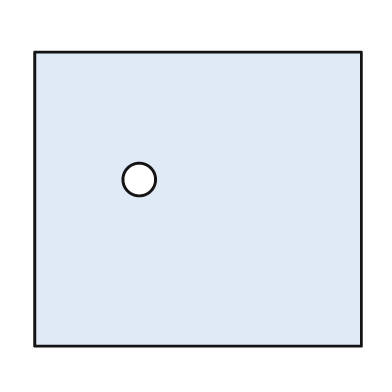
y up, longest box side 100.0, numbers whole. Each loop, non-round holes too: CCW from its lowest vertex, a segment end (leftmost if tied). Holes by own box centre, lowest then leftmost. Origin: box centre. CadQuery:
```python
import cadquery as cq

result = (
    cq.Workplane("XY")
    .moveTo(-50.0, -45.0)
    .lineTo(50.0, -45.0)
    .lineTo(50.0, 45.0)
    .lineTo(-50.0, 45.0)
    .close()
    .moveTo(-18.0, 6.0)
    .circle(5.0)
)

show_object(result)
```